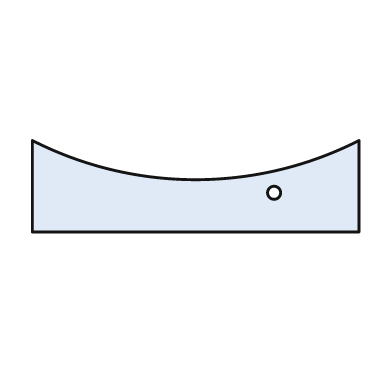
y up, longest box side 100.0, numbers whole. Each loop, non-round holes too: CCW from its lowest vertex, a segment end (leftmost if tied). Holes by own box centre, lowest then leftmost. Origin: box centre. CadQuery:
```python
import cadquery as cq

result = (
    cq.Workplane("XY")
    .moveTo(-50.0, -14.0)
    .lineTo(50.0, -14.0)
    .lineTo(50.0, 14.0)
    .threePointArc((0.0, 2.0), (-50.0, 14.0))
    .close()
    .moveTo(24.0, -2.0)
    .circle(2.0)
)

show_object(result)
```